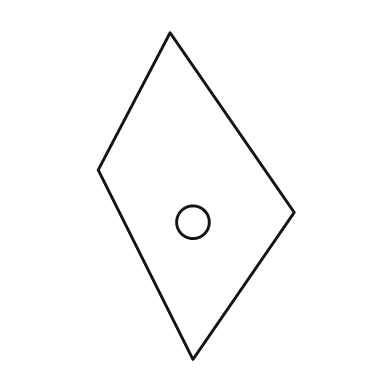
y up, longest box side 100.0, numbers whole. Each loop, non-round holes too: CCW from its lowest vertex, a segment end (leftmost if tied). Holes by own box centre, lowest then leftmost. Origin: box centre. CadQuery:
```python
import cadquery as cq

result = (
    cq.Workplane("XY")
    .moveTo(-1.0, -50.0)
    .lineTo(30.0, -5.0)
    .lineTo(-8.0, 50.0)
    .lineTo(-30.0, 8.0)
    .close()
    .moveTo(-1.0, -8.0)
    .circle(5.0)
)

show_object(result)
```